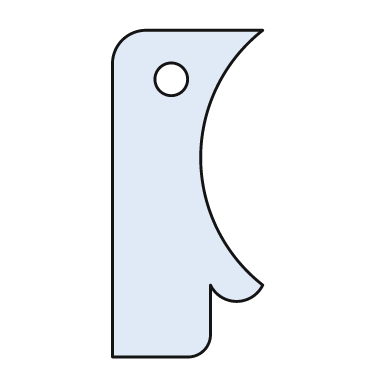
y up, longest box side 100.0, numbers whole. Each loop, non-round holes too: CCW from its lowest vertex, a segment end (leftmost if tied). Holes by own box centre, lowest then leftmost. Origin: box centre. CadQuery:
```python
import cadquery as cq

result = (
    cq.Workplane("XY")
    .moveTo(-23.0, -50.0)
    .lineTo(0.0, -50.0)
    .threePointArc((5.0, -48.0), (7.0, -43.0))
    .lineTo(7.0, -28.0)
    .threePointArc((15.0, -33.0), (23.0, -28.0))
    .threePointArc((4.0, 11.0), (23.0, 50.0))
    .lineTo(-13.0, 50.0)
    .threePointArc((-20.0, 47.0), (-23.0, 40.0))
    .close()
    .moveTo(-5.0, 35.0)
    .circle(5.0)
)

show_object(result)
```